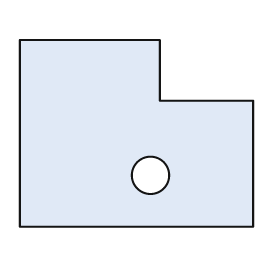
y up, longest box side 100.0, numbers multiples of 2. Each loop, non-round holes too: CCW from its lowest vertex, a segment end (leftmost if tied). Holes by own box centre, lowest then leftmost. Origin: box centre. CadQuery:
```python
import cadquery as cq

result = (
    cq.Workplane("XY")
    .moveTo(-50.0, -40.0)
    .lineTo(50.0, -40.0)
    .lineTo(50.0, 14.0)
    .lineTo(10.0, 14.0)
    .lineTo(10.0, 40.0)
    .lineTo(-50.0, 40.0)
    .close()
    .moveTo(6.0, -18.0)
    .circle(8.0)
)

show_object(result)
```